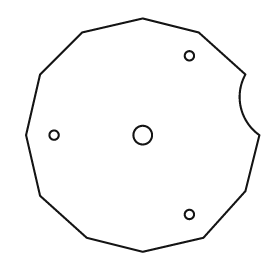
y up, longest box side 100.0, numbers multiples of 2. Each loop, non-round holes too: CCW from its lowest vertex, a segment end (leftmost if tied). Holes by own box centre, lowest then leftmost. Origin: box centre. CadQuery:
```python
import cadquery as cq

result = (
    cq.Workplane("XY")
    .moveTo(0.0, -50.0)
    .lineTo(26.0, -44.0)
    .lineTo(44.0, -24.0)
    .lineTo(50.0, 0.0)
    .threePointArc((42.0, 12.0), (44.0, 26.0))
    .lineTo(24.0, 44.0)
    .lineTo(0.0, 50.0)
    .lineTo(-26.0, 44.0)
    .lineTo(-44.0, 26.0)
    .lineTo(-50.0, 0.0)
    .lineTo(-44.0, -26.0)
    .lineTo(-24.0, -44.0)
    .close()
    .moveTo(20.0, -34.0)
    .circle(2.0)
    .moveTo(-38.0, 0.0)
    .circle(2.0)
    .moveTo(0.0, 0.0)
    .circle(4.0)
    .moveTo(20.0, 34.0)
    .circle(2.0)
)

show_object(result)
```